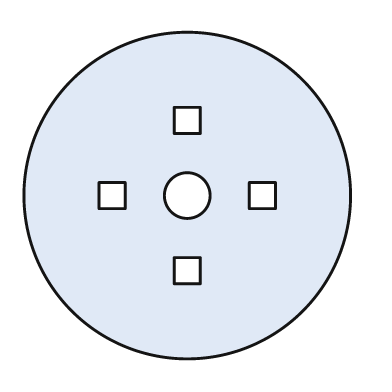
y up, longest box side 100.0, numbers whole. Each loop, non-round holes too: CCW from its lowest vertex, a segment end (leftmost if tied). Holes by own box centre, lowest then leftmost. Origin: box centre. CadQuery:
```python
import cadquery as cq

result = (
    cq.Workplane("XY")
    .moveTo(0.0, 0.0)
    .circle(50.0)
    .moveTo(-4.0, -27.0)
    .lineTo(4.0, -27.0)
    .lineTo(4.0, -19.0)
    .lineTo(-4.0, -19.0)
    .close()
    .moveTo(-27.0, -4.0)
    .lineTo(-19.0, -4.0)
    .lineTo(-19.0, 4.0)
    .lineTo(-27.0, 4.0)
    .close()
    .moveTo(0.0, 0.0)
    .circle(7.0)
    .moveTo(19.0, -4.0)
    .lineTo(27.0, -4.0)
    .lineTo(27.0, 4.0)
    .lineTo(19.0, 4.0)
    .close()
    .moveTo(-4.0, 19.0)
    .lineTo(4.0, 19.0)
    .lineTo(4.0, 27.0)
    .lineTo(-4.0, 27.0)
    .close()
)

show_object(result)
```